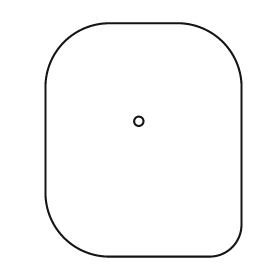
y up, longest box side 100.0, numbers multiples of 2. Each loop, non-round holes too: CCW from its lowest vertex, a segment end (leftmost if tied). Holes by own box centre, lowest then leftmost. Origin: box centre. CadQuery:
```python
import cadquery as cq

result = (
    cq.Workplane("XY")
    .moveTo(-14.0, -50.0)
    .lineTo(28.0, -50.0)
    .threePointArc((38.0, -46.0), (42.0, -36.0))
    .lineTo(42.0, 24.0)
    .threePointArc((34.0, 42.0), (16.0, 50.0))
    .lineTo(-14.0, 50.0)
    .threePointArc((-34.0, 42.0), (-42.0, 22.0))
    .lineTo(-42.0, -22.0)
    .threePointArc((-34.0, -42.0), (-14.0, -50.0))
    .close()
    .moveTo(-2.0, 8.0)
    .circle(2.0)
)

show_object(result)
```